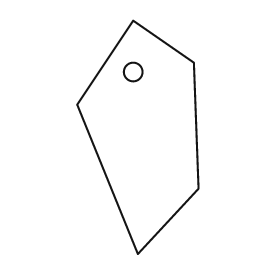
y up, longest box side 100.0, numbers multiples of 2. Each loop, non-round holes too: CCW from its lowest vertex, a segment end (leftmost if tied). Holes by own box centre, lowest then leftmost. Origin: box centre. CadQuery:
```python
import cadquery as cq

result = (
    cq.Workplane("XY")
    .moveTo(0.0, -50.0)
    .lineTo(26.0, -22.0)
    .lineTo(24.0, 32.0)
    .lineTo(-2.0, 50.0)
    .lineTo(-26.0, 14.0)
    .close()
    .moveTo(-2.0, 28.0)
    .circle(4.0)
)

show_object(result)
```